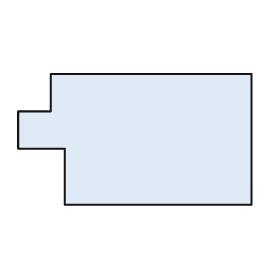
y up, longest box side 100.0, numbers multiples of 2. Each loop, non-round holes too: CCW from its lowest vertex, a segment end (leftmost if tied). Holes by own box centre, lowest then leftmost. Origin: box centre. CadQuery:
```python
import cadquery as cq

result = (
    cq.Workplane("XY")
    .moveTo(-30.0, -28.0)
    .lineTo(50.0, -28.0)
    .lineTo(50.0, 28.0)
    .lineTo(-36.0, 28.0)
    .lineTo(-36.0, 12.0)
    .lineTo(-50.0, 12.0)
    .lineTo(-50.0, -4.0)
    .lineTo(-30.0, -4.0)
    .close()
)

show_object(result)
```